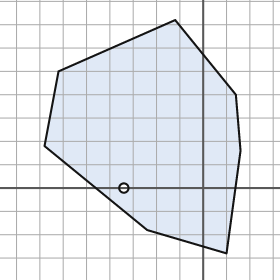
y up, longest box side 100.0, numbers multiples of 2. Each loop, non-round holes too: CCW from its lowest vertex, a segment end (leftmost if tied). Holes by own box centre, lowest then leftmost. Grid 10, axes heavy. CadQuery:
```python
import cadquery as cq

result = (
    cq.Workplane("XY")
    .moveTo(10.0, -28.0)
    .lineTo(16.0, 16.0)
    .lineTo(14.0, 40.0)
    .lineTo(-12.0, 72.0)
    .lineTo(-62.0, 50.0)
    .lineTo(-68.0, 18.0)
    .lineTo(-24.0, -18.0)
    .close()
    .moveTo(-34.0, 0.0)
    .circle(2.0)
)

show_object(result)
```